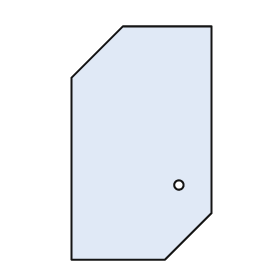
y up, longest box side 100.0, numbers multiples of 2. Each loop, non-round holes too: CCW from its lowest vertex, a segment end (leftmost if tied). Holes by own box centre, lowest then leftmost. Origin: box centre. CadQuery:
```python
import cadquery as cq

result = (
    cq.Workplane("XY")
    .moveTo(-30.0, -50.0)
    .lineTo(10.0, -50.0)
    .lineTo(30.0, -30.0)
    .lineTo(30.0, 50.0)
    .lineTo(-8.0, 50.0)
    .lineTo(-30.0, 28.0)
    .close()
    .moveTo(16.0, -18.0)
    .circle(2.0)
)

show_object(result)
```